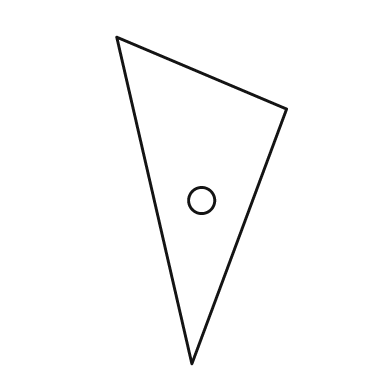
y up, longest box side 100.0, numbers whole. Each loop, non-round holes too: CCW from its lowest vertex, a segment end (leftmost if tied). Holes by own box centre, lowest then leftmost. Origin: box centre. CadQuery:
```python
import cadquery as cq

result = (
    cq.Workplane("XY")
    .moveTo(-3.0, -50.0)
    .lineTo(26.0, 28.0)
    .lineTo(-26.0, 50.0)
    .close()
    .moveTo(0.0, 0.0)
    .circle(4.0)
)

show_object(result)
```